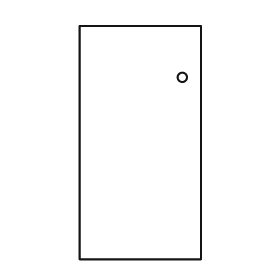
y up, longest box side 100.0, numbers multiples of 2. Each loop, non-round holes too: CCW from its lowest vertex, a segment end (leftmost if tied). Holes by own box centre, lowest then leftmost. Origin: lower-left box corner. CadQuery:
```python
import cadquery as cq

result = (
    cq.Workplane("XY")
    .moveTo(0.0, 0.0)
    .lineTo(52.0, 0.0)
    .lineTo(52.0, 100.0)
    .lineTo(0.0, 100.0)
    .close()
    .moveTo(44.0, 78.0)
    .circle(2.0)
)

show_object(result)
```